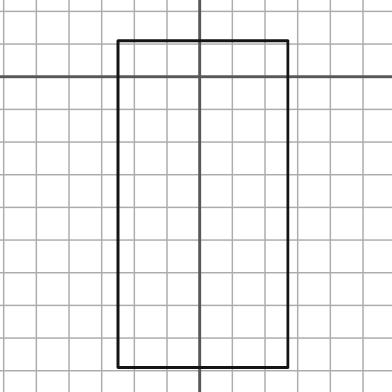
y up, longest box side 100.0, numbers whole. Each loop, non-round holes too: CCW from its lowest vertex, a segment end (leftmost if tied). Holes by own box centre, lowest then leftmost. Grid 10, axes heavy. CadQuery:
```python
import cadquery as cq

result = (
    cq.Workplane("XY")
    .moveTo(-25.0, -89.0)
    .lineTo(27.0, -89.0)
    .lineTo(27.0, 11.0)
    .lineTo(-25.0, 11.0)
    .close()
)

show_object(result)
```